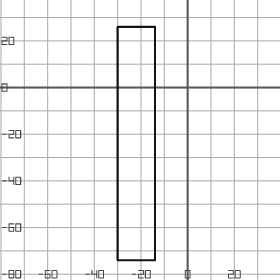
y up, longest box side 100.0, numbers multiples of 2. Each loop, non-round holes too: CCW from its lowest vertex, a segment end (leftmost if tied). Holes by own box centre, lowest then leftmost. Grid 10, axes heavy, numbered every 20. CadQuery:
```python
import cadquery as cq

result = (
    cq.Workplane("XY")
    .moveTo(-30.0, -74.0)
    .lineTo(-14.0, -74.0)
    .lineTo(-14.0, 26.0)
    .lineTo(-30.0, 26.0)
    .close()
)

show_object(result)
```